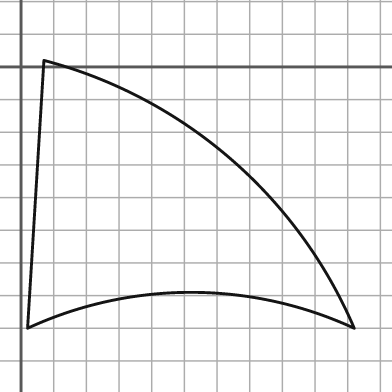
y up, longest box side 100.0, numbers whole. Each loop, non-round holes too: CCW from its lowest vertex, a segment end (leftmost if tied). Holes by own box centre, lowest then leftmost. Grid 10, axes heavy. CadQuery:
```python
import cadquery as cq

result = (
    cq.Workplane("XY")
    .moveTo(2.0, -80.0)
    .threePointArc((52.0, -69.0), (102.0, -80.0))
    .threePointArc((64.0, -28.0), (7.0, 2.0))
    .close()
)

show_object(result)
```